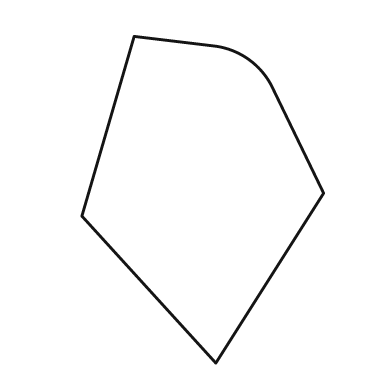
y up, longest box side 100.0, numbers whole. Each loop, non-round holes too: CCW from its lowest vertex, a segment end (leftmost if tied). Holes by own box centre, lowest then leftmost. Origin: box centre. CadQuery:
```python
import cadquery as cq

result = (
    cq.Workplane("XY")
    .moveTo(4.0, -50.0)
    .lineTo(37.0, 2.0)
    .lineTo(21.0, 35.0)
    .threePointArc((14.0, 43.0), (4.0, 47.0))
    .lineTo(-21.0, 50.0)
    .lineTo(-37.0, -5.0)
    .close()
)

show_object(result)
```